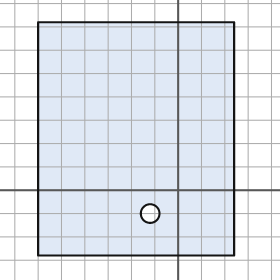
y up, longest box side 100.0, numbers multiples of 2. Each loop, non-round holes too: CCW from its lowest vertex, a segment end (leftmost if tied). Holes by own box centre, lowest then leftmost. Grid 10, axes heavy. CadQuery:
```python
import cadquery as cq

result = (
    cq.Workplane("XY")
    .moveTo(-60.0, -28.0)
    .lineTo(24.0, -28.0)
    .lineTo(24.0, 72.0)
    .lineTo(-60.0, 72.0)
    .close()
    .moveTo(-12.0, -10.0)
    .circle(4.0)
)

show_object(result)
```